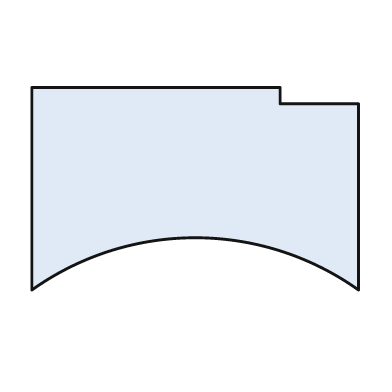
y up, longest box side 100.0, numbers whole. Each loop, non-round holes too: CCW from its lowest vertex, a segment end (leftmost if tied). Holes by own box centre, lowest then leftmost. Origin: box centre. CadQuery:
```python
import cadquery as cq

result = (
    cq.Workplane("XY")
    .moveTo(-50.0, -31.0)
    .threePointArc((0.0, -15.0), (50.0, -31.0))
    .lineTo(50.0, 26.0)
    .lineTo(26.0, 26.0)
    .lineTo(26.0, 31.0)
    .lineTo(-50.0, 31.0)
    .close()
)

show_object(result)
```